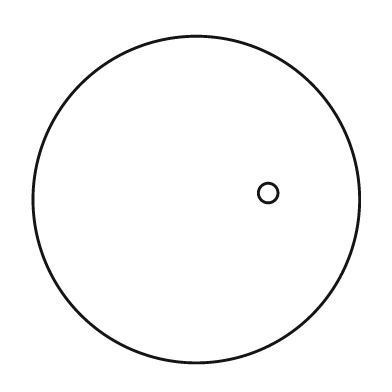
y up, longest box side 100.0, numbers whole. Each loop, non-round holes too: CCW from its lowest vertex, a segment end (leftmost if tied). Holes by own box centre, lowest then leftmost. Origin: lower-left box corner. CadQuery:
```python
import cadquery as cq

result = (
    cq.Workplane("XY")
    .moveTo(50.0, 50.0)
    .circle(50.0)
    .moveTo(72.0, 52.0)
    .circle(3.0)
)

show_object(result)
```